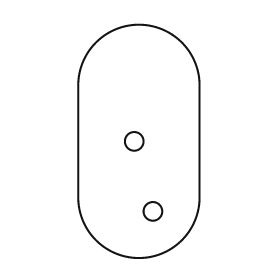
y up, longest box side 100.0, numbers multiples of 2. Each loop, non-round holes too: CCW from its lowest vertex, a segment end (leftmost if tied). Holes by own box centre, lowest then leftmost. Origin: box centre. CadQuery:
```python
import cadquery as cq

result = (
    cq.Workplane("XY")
    .moveTo(-26.0, -24.0)
    .threePointArc((0.0, -50.0), (26.0, -24.0))
    .lineTo(26.0, 24.0)
    .threePointArc((0.0, 50.0), (-26.0, 24.0))
    .close()
    .moveTo(6.0, -30.0)
    .circle(4.0)
    .moveTo(-2.0, 0.0)
    .circle(4.0)
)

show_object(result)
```